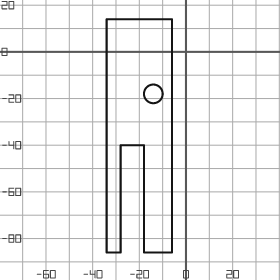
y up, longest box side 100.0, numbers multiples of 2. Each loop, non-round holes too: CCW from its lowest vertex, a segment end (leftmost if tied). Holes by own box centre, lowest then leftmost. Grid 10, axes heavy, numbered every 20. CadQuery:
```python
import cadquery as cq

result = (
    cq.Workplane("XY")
    .moveTo(-34.0, -86.0)
    .lineTo(-28.0, -86.0)
    .lineTo(-28.0, -40.0)
    .lineTo(-18.0, -40.0)
    .lineTo(-18.0, -86.0)
    .lineTo(-6.0, -86.0)
    .lineTo(-6.0, 14.0)
    .lineTo(-34.0, 14.0)
    .close()
    .moveTo(-14.0, -18.0)
    .circle(4.0)
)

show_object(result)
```